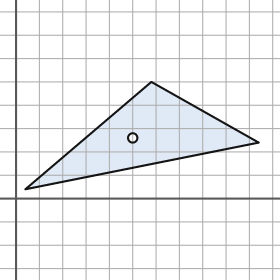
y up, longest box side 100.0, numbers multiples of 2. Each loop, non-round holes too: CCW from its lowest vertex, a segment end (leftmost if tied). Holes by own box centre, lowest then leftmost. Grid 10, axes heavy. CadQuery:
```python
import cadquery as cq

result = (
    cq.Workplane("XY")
    .moveTo(4.0, 4.0)
    .lineTo(104.0, 24.0)
    .lineTo(58.0, 50.0)
    .close()
    .moveTo(50.0, 26.0)
    .circle(2.0)
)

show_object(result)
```